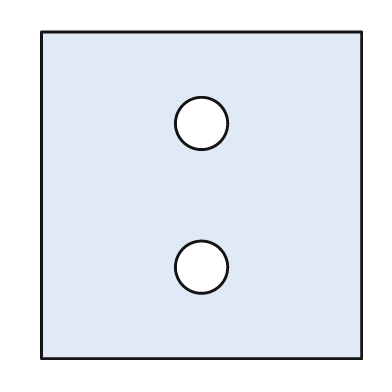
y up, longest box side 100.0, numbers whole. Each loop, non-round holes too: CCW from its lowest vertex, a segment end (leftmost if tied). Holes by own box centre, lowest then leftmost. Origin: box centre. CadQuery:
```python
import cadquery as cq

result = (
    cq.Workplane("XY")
    .moveTo(-49.0, -50.0)
    .lineTo(49.0, -50.0)
    .lineTo(49.0, 50.0)
    .lineTo(-49.0, 50.0)
    .close()
    .moveTo(0.0, -22.0)
    .circle(8.0)
    .moveTo(0.0, 22.0)
    .circle(8.0)
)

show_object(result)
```